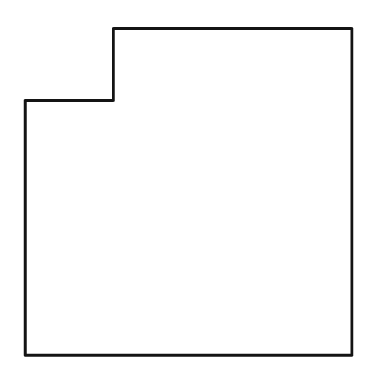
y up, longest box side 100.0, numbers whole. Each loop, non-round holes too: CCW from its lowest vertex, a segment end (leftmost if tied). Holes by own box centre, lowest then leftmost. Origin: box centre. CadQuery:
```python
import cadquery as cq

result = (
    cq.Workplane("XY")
    .moveTo(-50.0, -50.0)
    .lineTo(50.0, -50.0)
    .lineTo(50.0, 50.0)
    .lineTo(-23.0, 50.0)
    .lineTo(-23.0, 28.0)
    .lineTo(-50.0, 28.0)
    .close()
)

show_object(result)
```